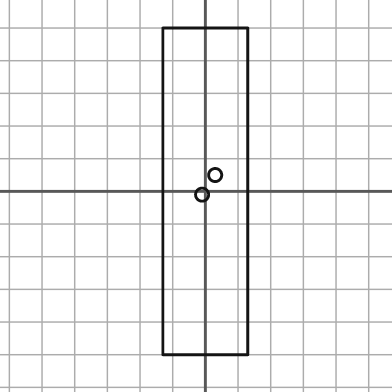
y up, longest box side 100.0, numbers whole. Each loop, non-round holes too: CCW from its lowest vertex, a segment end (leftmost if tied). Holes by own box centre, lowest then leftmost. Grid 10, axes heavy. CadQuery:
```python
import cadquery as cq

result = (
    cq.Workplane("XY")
    .moveTo(-13.0, -50.0)
    .lineTo(13.0, -50.0)
    .lineTo(13.0, 50.0)
    .lineTo(-13.0, 50.0)
    .close()
    .moveTo(-1.0, -1.0)
    .circle(2.0)
    .moveTo(3.0, 5.0)
    .circle(2.0)
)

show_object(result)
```